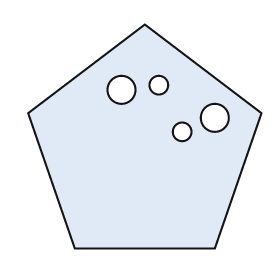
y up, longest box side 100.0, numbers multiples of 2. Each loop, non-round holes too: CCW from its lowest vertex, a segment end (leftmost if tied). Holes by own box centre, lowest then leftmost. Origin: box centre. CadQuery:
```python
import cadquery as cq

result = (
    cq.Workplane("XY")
    .moveTo(-30.0, -48.0)
    .lineTo(30.0, -48.0)
    .lineTo(50.0, 10.0)
    .lineTo(0.0, 48.0)
    .lineTo(-50.0, 10.0)
    .close()
    .moveTo(16.0, 2.0)
    .circle(4.0)
    .moveTo(30.0, 8.0)
    .circle(6.0)
    .moveTo(-10.0, 20.0)
    .circle(6.0)
    .moveTo(6.0, 22.0)
    .circle(4.0)
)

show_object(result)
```